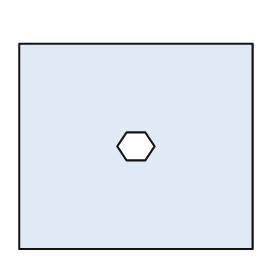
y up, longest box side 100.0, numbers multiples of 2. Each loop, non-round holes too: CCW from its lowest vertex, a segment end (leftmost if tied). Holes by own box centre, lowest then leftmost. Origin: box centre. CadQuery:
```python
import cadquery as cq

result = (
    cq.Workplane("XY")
    .moveTo(-50.0, -44.0)
    .lineTo(50.0, -44.0)
    .lineTo(50.0, 44.0)
    .lineTo(-50.0, 44.0)
    .close()
    .moveTo(-4.0, -6.0)
    .lineTo(4.0, -6.0)
    .lineTo(8.0, 0.0)
    .lineTo(4.0, 6.0)
    .lineTo(-4.0, 6.0)
    .lineTo(-8.0, 0.0)
    .close()
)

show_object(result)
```